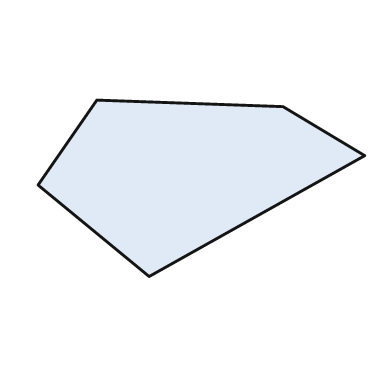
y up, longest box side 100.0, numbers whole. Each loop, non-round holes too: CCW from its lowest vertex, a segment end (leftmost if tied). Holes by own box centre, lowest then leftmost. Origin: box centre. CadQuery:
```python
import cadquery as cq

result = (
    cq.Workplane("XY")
    .moveTo(-16.0, -27.0)
    .lineTo(50.0, 10.0)
    .lineTo(25.0, 25.0)
    .lineTo(-32.0, 27.0)
    .lineTo(-50.0, 1.0)
    .close()
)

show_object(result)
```